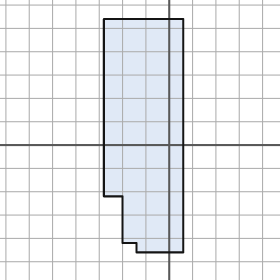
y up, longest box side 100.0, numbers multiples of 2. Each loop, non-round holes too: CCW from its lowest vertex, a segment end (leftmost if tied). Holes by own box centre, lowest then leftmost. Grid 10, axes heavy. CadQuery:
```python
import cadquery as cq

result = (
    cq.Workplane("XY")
    .moveTo(-14.0, -46.0)
    .lineTo(6.0, -46.0)
    .lineTo(6.0, 54.0)
    .lineTo(-28.0, 54.0)
    .lineTo(-28.0, -22.0)
    .lineTo(-20.0, -22.0)
    .lineTo(-20.0, -42.0)
    .lineTo(-14.0, -42.0)
    .close()
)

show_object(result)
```